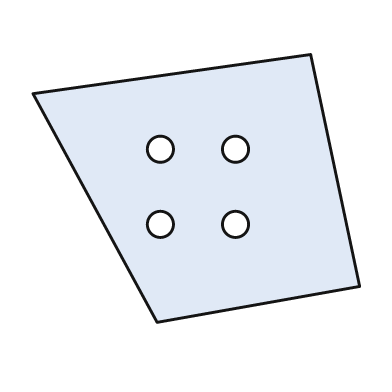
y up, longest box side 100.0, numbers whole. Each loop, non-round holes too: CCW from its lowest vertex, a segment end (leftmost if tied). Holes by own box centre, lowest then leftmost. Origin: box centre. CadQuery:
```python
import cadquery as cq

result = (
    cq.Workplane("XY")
    .moveTo(-12.0, -41.0)
    .lineTo(50.0, -30.0)
    .lineTo(35.0, 41.0)
    .lineTo(-50.0, 29.0)
    .close()
    .moveTo(-11.0, -11.0)
    .circle(4.0)
    .moveTo(12.0, -11.0)
    .circle(4.0)
    .moveTo(-11.0, 12.0)
    .circle(4.0)
    .moveTo(12.0, 12.0)
    .circle(4.0)
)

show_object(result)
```